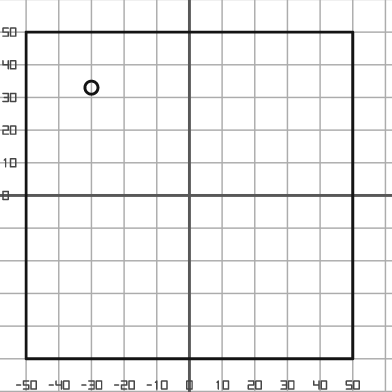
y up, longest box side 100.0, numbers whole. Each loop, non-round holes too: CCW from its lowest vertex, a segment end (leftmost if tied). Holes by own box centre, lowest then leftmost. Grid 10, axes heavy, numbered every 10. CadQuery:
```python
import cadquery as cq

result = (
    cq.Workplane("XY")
    .moveTo(-50.0, -50.0)
    .lineTo(50.0, -50.0)
    .lineTo(50.0, 50.0)
    .lineTo(-50.0, 50.0)
    .close()
    .moveTo(-30.0, 33.0)
    .circle(2.0)
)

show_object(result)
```